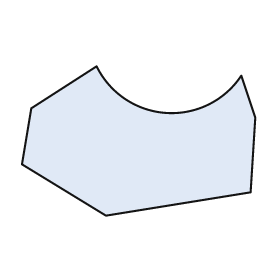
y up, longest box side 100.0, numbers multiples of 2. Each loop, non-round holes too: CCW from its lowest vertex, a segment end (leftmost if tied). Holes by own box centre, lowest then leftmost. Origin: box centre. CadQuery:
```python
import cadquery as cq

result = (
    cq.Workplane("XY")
    .moveTo(-14.0, -32.0)
    .lineTo(48.0, -22.0)
    .lineTo(50.0, 10.0)
    .lineTo(44.0, 28.0)
    .threePointArc((12.0, 12.0), (-18.0, 32.0))
    .lineTo(-46.0, 14.0)
    .lineTo(-50.0, -10.0)
    .close()
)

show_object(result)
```